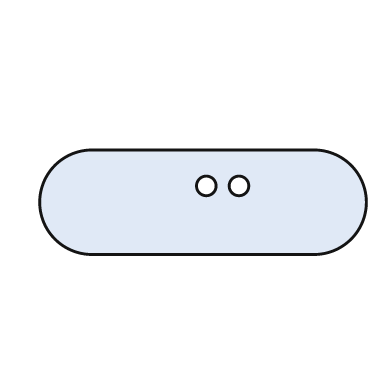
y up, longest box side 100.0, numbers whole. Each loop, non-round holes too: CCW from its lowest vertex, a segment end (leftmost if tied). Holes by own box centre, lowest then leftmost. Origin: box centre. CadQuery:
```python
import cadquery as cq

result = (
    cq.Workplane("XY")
    .moveTo(-34.0, -16.0)
    .lineTo(34.0, -16.0)
    .threePointArc((50.0, 0.0), (34.0, 16.0))
    .lineTo(-34.0, 16.0)
    .threePointArc((-50.0, 0.0), (-34.0, -16.0))
    .close()
    .moveTo(1.0, 5.0)
    .circle(3.0)
    .moveTo(11.0, 5.0)
    .circle(3.0)
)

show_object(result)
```